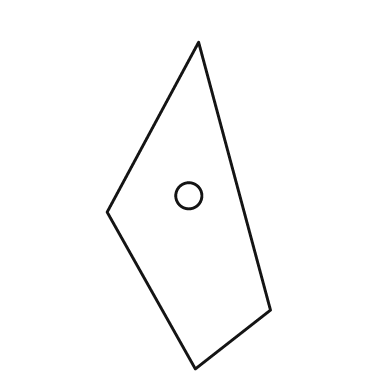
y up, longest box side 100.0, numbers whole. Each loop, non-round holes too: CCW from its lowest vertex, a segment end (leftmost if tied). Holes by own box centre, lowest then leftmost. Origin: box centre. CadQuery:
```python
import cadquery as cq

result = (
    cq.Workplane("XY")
    .moveTo(2.0, -50.0)
    .lineTo(25.0, -32.0)
    .lineTo(3.0, 50.0)
    .lineTo(-25.0, -2.0)
    .close()
    .moveTo(0.0, 3.0)
    .circle(4.0)
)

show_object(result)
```